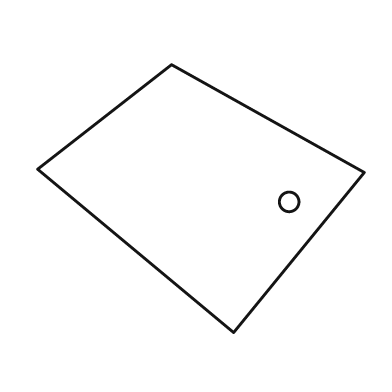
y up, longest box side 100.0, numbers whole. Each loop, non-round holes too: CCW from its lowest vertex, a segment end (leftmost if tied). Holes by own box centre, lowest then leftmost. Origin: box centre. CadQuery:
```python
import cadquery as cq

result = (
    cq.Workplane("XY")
    .moveTo(10.0, -41.0)
    .lineTo(50.0, 8.0)
    .lineTo(-9.0, 41.0)
    .lineTo(-50.0, 9.0)
    .close()
    .moveTo(27.0, -1.0)
    .circle(3.0)
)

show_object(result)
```